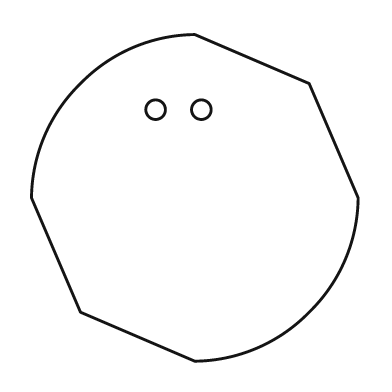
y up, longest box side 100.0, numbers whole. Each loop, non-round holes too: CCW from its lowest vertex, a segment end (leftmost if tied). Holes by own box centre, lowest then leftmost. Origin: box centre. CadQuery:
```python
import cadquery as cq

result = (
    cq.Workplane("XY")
    .moveTo(0.0, -50.0)
    .threePointArc((19.0, -46.0), (35.0, -35.0))
    .threePointArc((46.0, -19.0), (50.0, 0.0))
    .lineTo(35.0, 35.0)
    .lineTo(0.0, 50.0)
    .threePointArc((-19.0, 46.0), (-35.0, 35.0))
    .threePointArc((-46.0, 19.0), (-50.0, 0.0))
    .lineTo(-35.0, -35.0)
    .close()
    .moveTo(-12.0, 27.0)
    .circle(3.0)
    .moveTo(2.0, 27.0)
    .circle(3.0)
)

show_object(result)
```